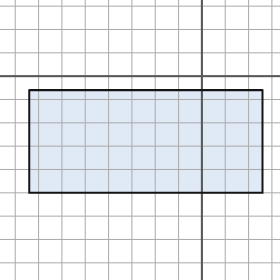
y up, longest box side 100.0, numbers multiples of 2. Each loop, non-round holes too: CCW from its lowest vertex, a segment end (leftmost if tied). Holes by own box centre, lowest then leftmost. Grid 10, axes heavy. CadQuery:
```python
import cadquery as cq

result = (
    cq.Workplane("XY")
    .moveTo(-74.0, -50.0)
    .lineTo(26.0, -50.0)
    .lineTo(26.0, -6.0)
    .lineTo(-74.0, -6.0)
    .close()
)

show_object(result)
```